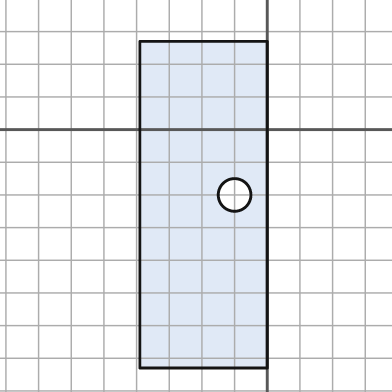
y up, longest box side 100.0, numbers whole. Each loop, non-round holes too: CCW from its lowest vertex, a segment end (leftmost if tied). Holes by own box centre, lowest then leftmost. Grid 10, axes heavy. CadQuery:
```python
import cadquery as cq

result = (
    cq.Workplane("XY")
    .moveTo(-39.0, -73.0)
    .lineTo(0.0, -73.0)
    .lineTo(0.0, 27.0)
    .lineTo(-39.0, 27.0)
    .close()
    .moveTo(-10.0, -20.0)
    .circle(5.0)
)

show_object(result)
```